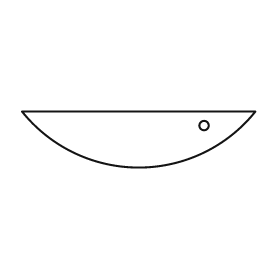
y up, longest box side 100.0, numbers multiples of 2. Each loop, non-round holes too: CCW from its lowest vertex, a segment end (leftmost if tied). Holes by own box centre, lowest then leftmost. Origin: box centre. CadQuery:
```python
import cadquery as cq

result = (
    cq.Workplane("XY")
    .moveTo(-50.0, 12.0)
    .threePointArc((0.0, -12.0), (50.0, 12.0))
    .close()
    .moveTo(28.0, 6.0)
    .circle(2.0)
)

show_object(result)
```